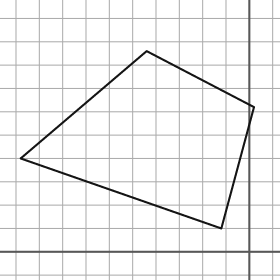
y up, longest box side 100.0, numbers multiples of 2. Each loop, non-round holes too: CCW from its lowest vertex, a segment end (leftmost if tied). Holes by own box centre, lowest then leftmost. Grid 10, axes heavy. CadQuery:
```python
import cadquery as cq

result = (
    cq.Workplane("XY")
    .moveTo(-12.0, 10.0)
    .lineTo(2.0, 62.0)
    .lineTo(-44.0, 86.0)
    .lineTo(-98.0, 40.0)
    .close()
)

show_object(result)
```